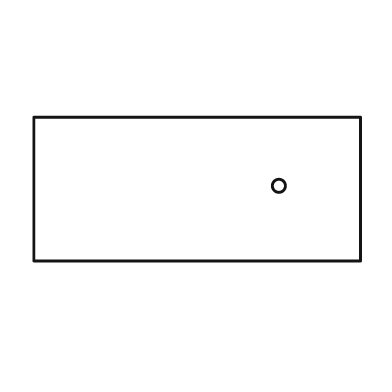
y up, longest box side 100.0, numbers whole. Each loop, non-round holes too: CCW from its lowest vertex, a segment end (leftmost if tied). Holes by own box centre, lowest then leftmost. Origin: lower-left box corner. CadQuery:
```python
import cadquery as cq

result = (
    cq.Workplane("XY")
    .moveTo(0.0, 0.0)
    .lineTo(100.0, 0.0)
    .lineTo(100.0, 44.0)
    .lineTo(0.0, 44.0)
    .close()
    .moveTo(75.0, 23.0)
    .circle(2.0)
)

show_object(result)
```